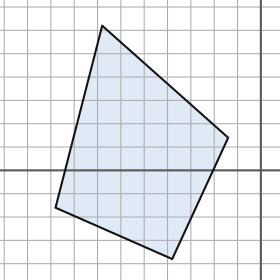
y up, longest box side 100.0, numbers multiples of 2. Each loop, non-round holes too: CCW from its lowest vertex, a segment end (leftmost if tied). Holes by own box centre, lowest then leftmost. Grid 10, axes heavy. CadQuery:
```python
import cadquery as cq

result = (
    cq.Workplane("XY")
    .moveTo(-38.0, -38.0)
    .lineTo(-14.0, 14.0)
    .lineTo(-68.0, 62.0)
    .lineTo(-88.0, -16.0)
    .close()
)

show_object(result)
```